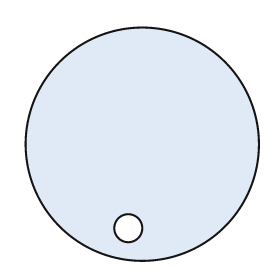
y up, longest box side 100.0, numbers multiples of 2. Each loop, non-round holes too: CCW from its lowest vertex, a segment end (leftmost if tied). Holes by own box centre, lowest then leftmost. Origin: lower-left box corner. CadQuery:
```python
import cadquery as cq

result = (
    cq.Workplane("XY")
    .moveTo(50.0, 50.0)
    .circle(50.0)
    .moveTo(44.0, 14.0)
    .circle(6.0)
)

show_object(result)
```